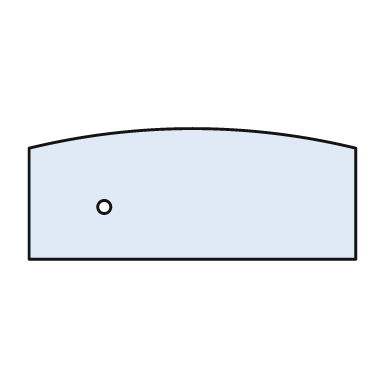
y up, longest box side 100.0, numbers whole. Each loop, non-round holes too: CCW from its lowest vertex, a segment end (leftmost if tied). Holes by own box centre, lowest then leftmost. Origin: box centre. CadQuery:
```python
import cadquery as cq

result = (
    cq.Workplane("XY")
    .moveTo(-50.0, -20.0)
    .lineTo(50.0, -20.0)
    .lineTo(50.0, 14.0)
    .threePointArc((0.0, 20.0), (-50.0, 14.0))
    .close()
    .moveTo(-27.0, -4.0)
    .circle(2.0)
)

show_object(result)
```